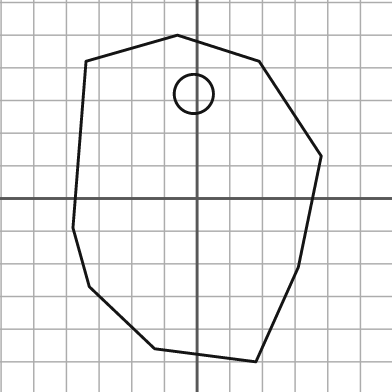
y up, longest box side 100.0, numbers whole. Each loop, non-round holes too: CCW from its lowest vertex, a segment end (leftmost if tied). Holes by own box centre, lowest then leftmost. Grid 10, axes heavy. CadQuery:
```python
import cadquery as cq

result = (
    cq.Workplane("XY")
    .moveTo(18.0, -50.0)
    .lineTo(31.0, -21.0)
    .lineTo(38.0, 13.0)
    .lineTo(19.0, 42.0)
    .lineTo(-6.0, 50.0)
    .lineTo(-34.0, 42.0)
    .lineTo(-38.0, -9.0)
    .lineTo(-33.0, -27.0)
    .lineTo(-13.0, -46.0)
    .close()
    .moveTo(-1.0, 32.0)
    .circle(6.0)
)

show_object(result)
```